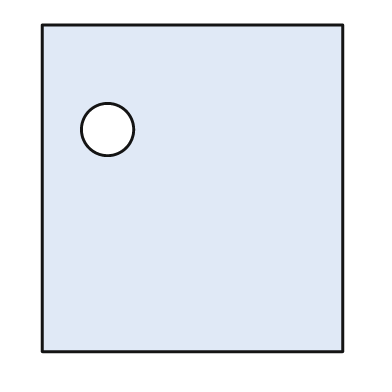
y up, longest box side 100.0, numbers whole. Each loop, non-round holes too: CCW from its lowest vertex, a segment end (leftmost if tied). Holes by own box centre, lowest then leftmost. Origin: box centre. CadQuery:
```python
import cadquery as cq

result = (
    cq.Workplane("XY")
    .moveTo(-46.0, -50.0)
    .lineTo(46.0, -50.0)
    .lineTo(46.0, 50.0)
    .lineTo(-46.0, 50.0)
    .close()
    .moveTo(-26.0, 18.0)
    .circle(8.0)
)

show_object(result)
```